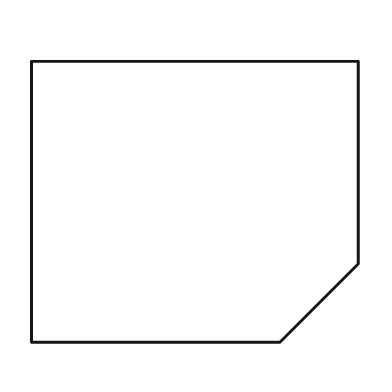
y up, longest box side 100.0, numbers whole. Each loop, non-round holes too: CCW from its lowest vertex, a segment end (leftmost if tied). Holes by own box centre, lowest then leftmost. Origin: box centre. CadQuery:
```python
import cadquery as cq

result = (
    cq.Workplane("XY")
    .moveTo(-50.0, -43.0)
    .lineTo(26.0, -43.0)
    .lineTo(50.0, -19.0)
    .lineTo(50.0, 43.0)
    .lineTo(-50.0, 43.0)
    .close()
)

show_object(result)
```